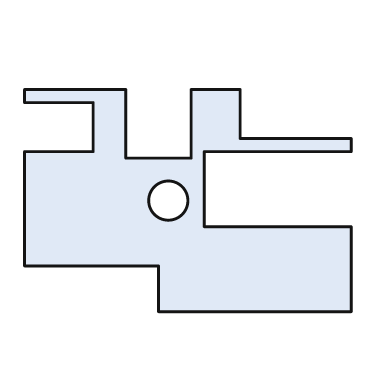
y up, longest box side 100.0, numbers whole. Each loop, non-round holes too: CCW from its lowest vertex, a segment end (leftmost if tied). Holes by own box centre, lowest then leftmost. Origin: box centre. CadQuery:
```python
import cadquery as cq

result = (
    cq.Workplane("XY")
    .moveTo(-9.0, -34.0)
    .lineTo(50.0, -34.0)
    .lineTo(50.0, -8.0)
    .lineTo(5.0, -8.0)
    .lineTo(5.0, 15.0)
    .lineTo(50.0, 15.0)
    .lineTo(50.0, 19.0)
    .lineTo(16.0, 19.0)
    .lineTo(16.0, 34.0)
    .lineTo(1.0, 34.0)
    .lineTo(1.0, 13.0)
    .lineTo(-19.0, 13.0)
    .lineTo(-19.0, 34.0)
    .lineTo(-50.0, 34.0)
    .lineTo(-50.0, 30.0)
    .lineTo(-29.0, 30.0)
    .lineTo(-29.0, 15.0)
    .lineTo(-50.0, 15.0)
    .lineTo(-50.0, -20.0)
    .lineTo(-9.0, -20.0)
    .close()
    .moveTo(-6.0, 0.0)
    .circle(6.0)
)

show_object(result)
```